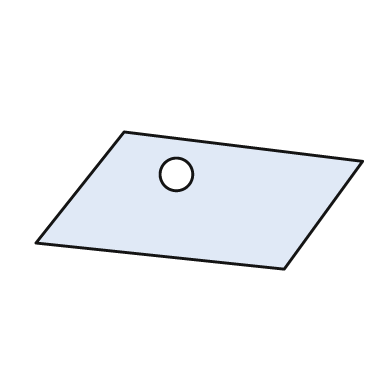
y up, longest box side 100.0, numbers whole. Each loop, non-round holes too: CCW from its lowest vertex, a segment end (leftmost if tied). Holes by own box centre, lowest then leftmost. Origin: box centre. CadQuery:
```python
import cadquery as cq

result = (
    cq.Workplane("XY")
    .moveTo(26.0, -21.0)
    .lineTo(50.0, 12.0)
    .lineTo(-23.0, 21.0)
    .lineTo(-50.0, -13.0)
    .close()
    .moveTo(-7.0, 8.0)
    .circle(5.0)
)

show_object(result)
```